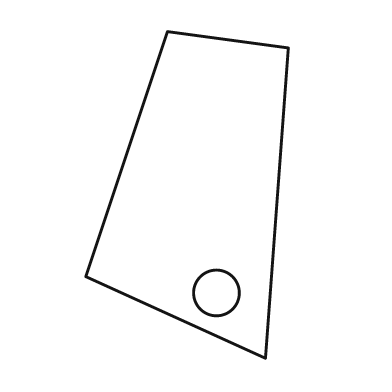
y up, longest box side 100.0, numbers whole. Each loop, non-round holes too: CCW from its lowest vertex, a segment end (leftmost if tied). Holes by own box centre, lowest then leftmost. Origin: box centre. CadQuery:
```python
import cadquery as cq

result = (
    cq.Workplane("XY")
    .moveTo(24.0, -50.0)
    .lineTo(31.0, 45.0)
    .lineTo(-6.0, 50.0)
    .lineTo(-31.0, -25.0)
    .close()
    .moveTo(9.0, -30.0)
    .circle(7.0)
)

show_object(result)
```